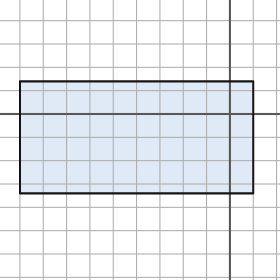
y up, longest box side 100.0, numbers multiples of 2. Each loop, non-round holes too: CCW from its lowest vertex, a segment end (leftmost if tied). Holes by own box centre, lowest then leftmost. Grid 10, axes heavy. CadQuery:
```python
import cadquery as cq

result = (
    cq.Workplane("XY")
    .moveTo(-90.0, -34.0)
    .lineTo(10.0, -34.0)
    .lineTo(10.0, 14.0)
    .lineTo(-90.0, 14.0)
    .close()
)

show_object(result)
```